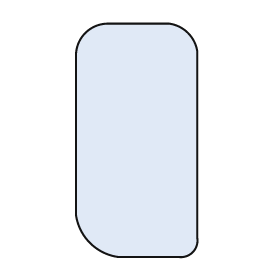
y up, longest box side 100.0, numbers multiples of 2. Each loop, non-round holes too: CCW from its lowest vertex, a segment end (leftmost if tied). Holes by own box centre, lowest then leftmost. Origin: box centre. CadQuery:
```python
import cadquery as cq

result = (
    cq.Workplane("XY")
    .moveTo(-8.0, -50.0)
    .lineTo(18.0, -50.0)
    .threePointArc((24.0, -48.0), (26.0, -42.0))
    .lineTo(26.0, 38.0)
    .threePointArc((22.0, 46.0), (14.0, 50.0))
    .lineTo(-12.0, 50.0)
    .threePointArc((-22.0, 46.0), (-26.0, 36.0))
    .lineTo(-26.0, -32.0)
    .threePointArc((-20.0, -44.0), (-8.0, -50.0))
    .close()
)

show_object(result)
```